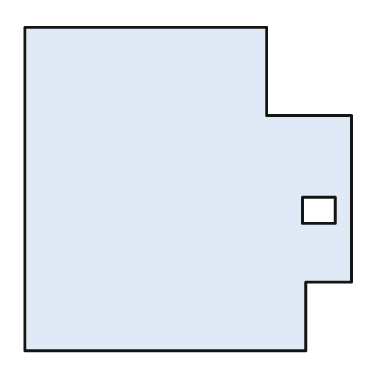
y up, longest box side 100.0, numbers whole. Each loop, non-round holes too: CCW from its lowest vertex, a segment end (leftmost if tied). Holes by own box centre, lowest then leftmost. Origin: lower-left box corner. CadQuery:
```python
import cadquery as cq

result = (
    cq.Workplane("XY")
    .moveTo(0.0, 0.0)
    .lineTo(86.0, 0.0)
    .lineTo(86.0, 21.0)
    .lineTo(100.0, 21.0)
    .lineTo(100.0, 72.0)
    .lineTo(74.0, 72.0)
    .lineTo(74.0, 99.0)
    .lineTo(0.0, 99.0)
    .close()
    .moveTo(85.0, 39.0)
    .lineTo(95.0, 39.0)
    .lineTo(95.0, 47.0)
    .lineTo(85.0, 47.0)
    .close()
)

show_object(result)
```